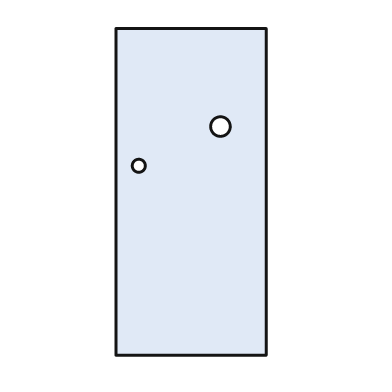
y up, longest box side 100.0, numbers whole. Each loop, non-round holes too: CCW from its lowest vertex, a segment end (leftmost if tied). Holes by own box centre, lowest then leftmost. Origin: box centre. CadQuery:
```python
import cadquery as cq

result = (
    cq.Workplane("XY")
    .moveTo(-23.0, -50.0)
    .lineTo(23.0, -50.0)
    .lineTo(23.0, 50.0)
    .lineTo(-23.0, 50.0)
    .close()
    .moveTo(-16.0, 8.0)
    .circle(2.0)
    .moveTo(9.0, 20.0)
    .circle(3.0)
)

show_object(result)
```